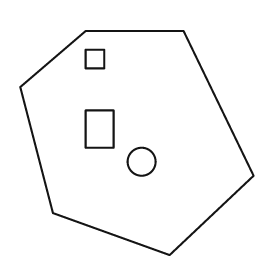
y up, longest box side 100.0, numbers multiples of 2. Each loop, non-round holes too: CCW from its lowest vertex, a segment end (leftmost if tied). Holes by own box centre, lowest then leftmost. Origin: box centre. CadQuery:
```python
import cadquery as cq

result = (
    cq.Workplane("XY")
    .moveTo(14.0, -48.0)
    .lineTo(50.0, -14.0)
    .lineTo(20.0, 48.0)
    .lineTo(-22.0, 48.0)
    .lineTo(-50.0, 24.0)
    .lineTo(-36.0, -30.0)
    .close()
    .moveTo(2.0, -8.0)
    .circle(6.0)
    .moveTo(-22.0, -2.0)
    .lineTo(-10.0, -2.0)
    .lineTo(-10.0, 14.0)
    .lineTo(-22.0, 14.0)
    .close()
    .moveTo(-22.0, 32.0)
    .lineTo(-14.0, 32.0)
    .lineTo(-14.0, 40.0)
    .lineTo(-22.0, 40.0)
    .close()
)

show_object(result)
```